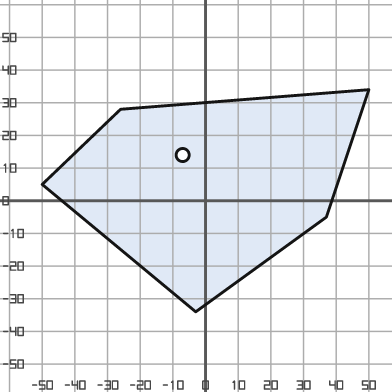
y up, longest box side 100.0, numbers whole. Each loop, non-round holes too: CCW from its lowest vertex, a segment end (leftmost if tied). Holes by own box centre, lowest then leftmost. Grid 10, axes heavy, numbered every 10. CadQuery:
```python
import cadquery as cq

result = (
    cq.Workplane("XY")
    .moveTo(-3.0, -34.0)
    .lineTo(37.0, -5.0)
    .lineTo(50.0, 34.0)
    .lineTo(-26.0, 28.0)
    .lineTo(-50.0, 5.0)
    .close()
    .moveTo(-7.0, 14.0)
    .circle(2.0)
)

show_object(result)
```